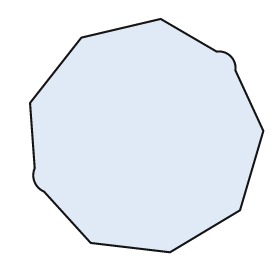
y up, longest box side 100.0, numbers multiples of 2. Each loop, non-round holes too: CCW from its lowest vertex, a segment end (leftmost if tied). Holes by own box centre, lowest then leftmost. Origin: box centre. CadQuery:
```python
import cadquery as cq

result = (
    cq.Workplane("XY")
    .moveTo(10.0, -50.0)
    .lineTo(40.0, -32.0)
    .lineTo(50.0, 2.0)
    .lineTo(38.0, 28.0)
    .threePointArc((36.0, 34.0), (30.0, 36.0))
    .lineTo(6.0, 50.0)
    .lineTo(-28.0, 42.0)
    .lineTo(-50.0, 14.0)
    .lineTo(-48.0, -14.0)
    .threePointArc((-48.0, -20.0), (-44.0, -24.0))
    .lineTo(-24.0, -46.0)
    .close()
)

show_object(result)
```